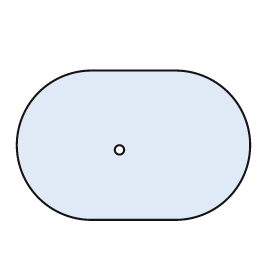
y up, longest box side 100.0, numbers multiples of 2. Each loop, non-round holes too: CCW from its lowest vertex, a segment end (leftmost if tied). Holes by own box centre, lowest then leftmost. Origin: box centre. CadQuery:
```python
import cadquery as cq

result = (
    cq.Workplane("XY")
    .moveTo(-18.0, -32.0)
    .lineTo(18.0, -32.0)
    .threePointArc((50.0, 0.0), (18.0, 32.0))
    .lineTo(-18.0, 32.0)
    .threePointArc((-50.0, 0.0), (-18.0, -32.0))
    .close()
    .moveTo(-6.0, -2.0)
    .circle(2.0)
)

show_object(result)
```